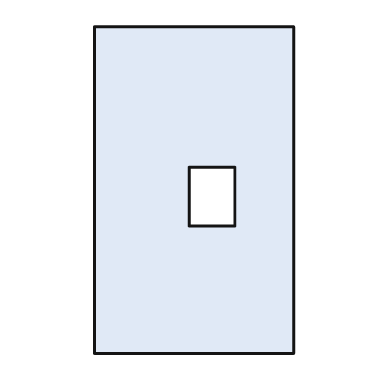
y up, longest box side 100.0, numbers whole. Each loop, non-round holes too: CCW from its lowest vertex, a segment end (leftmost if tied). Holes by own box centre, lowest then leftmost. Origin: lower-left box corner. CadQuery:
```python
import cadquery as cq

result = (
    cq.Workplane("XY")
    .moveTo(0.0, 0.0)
    .lineTo(61.0, 0.0)
    .lineTo(61.0, 100.0)
    .lineTo(0.0, 100.0)
    .close()
    .moveTo(29.0, 39.0)
    .lineTo(43.0, 39.0)
    .lineTo(43.0, 57.0)
    .lineTo(29.0, 57.0)
    .close()
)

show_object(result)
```